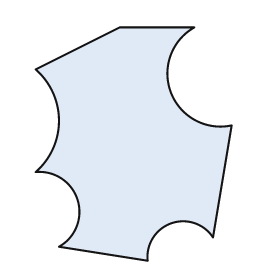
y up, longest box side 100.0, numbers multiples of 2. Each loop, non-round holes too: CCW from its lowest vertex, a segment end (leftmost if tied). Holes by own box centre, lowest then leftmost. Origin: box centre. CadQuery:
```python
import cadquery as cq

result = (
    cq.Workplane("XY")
    .moveTo(6.0, -50.0)
    .threePointArc((16.0, -34.0), (34.0, -40.0))
    .lineTo(42.0, 8.0)
    .threePointArc((16.0, 22.0), (26.0, 50.0))
    .lineTo(-6.0, 50.0)
    .lineTo(-42.0, 32.0)
    .threePointArc((-32.0, 10.0), (-42.0, -12.0))
    .threePointArc((-24.0, -24.0), (-32.0, -44.0))
    .close()
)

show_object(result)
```